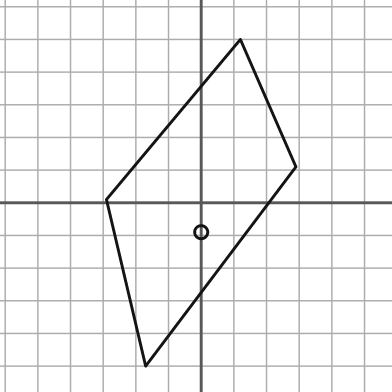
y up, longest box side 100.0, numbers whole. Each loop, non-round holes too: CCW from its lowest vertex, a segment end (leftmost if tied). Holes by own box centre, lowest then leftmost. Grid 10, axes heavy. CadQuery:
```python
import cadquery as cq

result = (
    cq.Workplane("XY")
    .moveTo(-17.0, -50.0)
    .lineTo(29.0, 11.0)
    .lineTo(12.0, 50.0)
    .lineTo(-29.0, 1.0)
    .close()
    .moveTo(0.0, -9.0)
    .circle(2.0)
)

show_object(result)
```